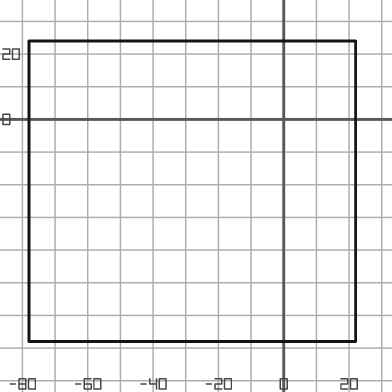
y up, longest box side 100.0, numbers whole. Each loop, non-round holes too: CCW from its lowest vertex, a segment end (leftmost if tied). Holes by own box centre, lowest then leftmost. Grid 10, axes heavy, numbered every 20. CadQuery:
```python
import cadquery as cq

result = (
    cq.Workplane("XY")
    .moveTo(-78.0, -68.0)
    .lineTo(22.0, -68.0)
    .lineTo(22.0, 24.0)
    .lineTo(-78.0, 24.0)
    .close()
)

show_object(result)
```